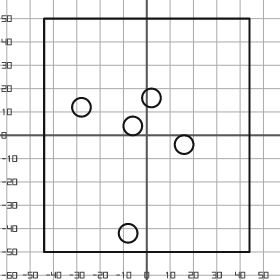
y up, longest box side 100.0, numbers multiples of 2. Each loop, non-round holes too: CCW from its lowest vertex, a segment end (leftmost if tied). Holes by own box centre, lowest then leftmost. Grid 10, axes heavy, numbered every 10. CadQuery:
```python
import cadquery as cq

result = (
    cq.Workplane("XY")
    .moveTo(-44.0, -50.0)
    .lineTo(44.0, -50.0)
    .lineTo(44.0, 50.0)
    .lineTo(-44.0, 50.0)
    .close()
    .moveTo(-8.0, -42.0)
    .circle(4.0)
    .moveTo(16.0, -4.0)
    .circle(4.0)
    .moveTo(-6.0, 4.0)
    .circle(4.0)
    .moveTo(-28.0, 12.0)
    .circle(4.0)
    .moveTo(2.0, 16.0)
    .circle(4.0)
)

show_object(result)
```